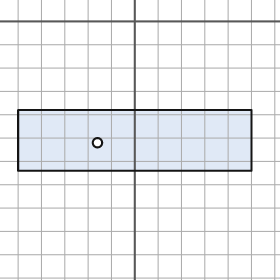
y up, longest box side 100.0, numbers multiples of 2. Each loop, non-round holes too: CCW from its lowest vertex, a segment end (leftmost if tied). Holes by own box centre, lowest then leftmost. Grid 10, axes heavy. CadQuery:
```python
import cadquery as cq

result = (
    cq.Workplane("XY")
    .moveTo(-50.0, -64.0)
    .lineTo(50.0, -64.0)
    .lineTo(50.0, -38.0)
    .lineTo(-50.0, -38.0)
    .close()
    .moveTo(-16.0, -52.0)
    .circle(2.0)
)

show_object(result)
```